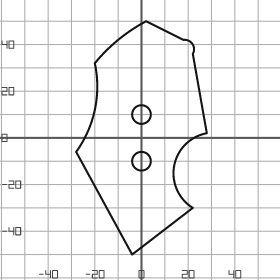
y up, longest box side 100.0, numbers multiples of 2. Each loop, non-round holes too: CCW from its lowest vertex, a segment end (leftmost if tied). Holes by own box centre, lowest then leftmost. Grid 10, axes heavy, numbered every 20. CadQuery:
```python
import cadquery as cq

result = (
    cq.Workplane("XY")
    .moveTo(-4.0, -50.0)
    .lineTo(22.0, -30.0)
    .threePointArc((14.0, -12.0), (28.0, 2.0))
    .lineTo(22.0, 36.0)
    .threePointArc((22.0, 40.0), (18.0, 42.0))
    .lineTo(2.0, 50.0)
    .threePointArc((-10.0, 42.0), (-20.0, 32.0))
    .threePointArc((-20.0, 12.0), (-28.0, -6.0))
    .close()
    .moveTo(0.0, -10.0)
    .circle(4.0)
    .moveTo(0.0, 10.0)
    .circle(4.0)
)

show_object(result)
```